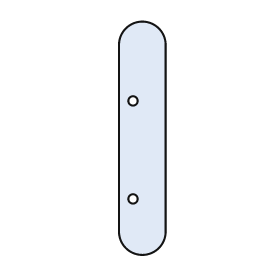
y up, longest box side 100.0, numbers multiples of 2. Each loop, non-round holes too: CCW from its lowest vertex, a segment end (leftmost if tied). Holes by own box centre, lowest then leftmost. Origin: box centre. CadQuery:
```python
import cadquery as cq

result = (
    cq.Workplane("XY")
    .moveTo(-10.0, -40.0)
    .threePointArc((0.0, -50.0), (10.0, -40.0))
    .lineTo(10.0, 40.0)
    .threePointArc((0.0, 50.0), (-10.0, 40.0))
    .close()
    .moveTo(-4.0, -26.0)
    .circle(2.0)
    .moveTo(-4.0, 16.0)
    .circle(2.0)
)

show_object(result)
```